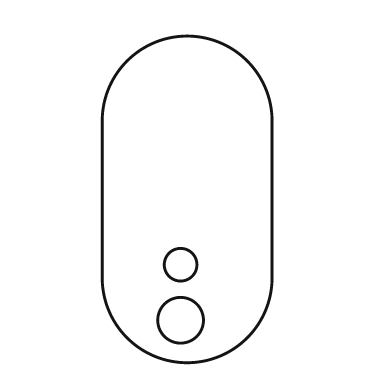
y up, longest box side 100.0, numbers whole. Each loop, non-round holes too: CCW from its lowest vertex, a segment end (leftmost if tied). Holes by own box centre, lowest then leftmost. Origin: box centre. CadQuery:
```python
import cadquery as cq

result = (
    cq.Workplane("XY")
    .moveTo(-26.0, -24.0)
    .threePointArc((0.0, -50.0), (26.0, -24.0))
    .lineTo(26.0, 24.0)
    .threePointArc((0.0, 50.0), (-26.0, 24.0))
    .close()
    .moveTo(-2.0, -37.0)
    .circle(7.0)
    .moveTo(-2.0, -20.0)
    .circle(5.0)
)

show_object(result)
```